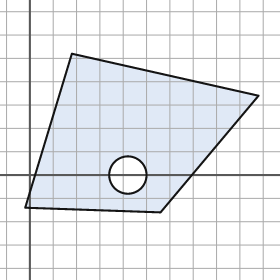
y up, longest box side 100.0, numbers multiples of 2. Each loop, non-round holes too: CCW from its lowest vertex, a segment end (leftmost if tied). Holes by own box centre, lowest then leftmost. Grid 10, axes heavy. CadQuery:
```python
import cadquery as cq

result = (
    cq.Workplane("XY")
    .moveTo(56.0, -16.0)
    .lineTo(98.0, 34.0)
    .lineTo(18.0, 52.0)
    .lineTo(-2.0, -14.0)
    .close()
    .moveTo(42.0, 0.0)
    .circle(8.0)
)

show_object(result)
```